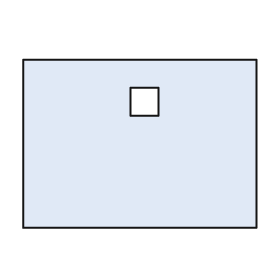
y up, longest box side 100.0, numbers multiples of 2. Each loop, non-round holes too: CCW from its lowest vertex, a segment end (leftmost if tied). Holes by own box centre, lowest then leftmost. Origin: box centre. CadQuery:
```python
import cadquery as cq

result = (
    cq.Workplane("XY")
    .moveTo(-50.0, -36.0)
    .lineTo(50.0, -36.0)
    .lineTo(50.0, 36.0)
    .lineTo(-50.0, 36.0)
    .close()
    .moveTo(-4.0, 12.0)
    .lineTo(8.0, 12.0)
    .lineTo(8.0, 24.0)
    .lineTo(-4.0, 24.0)
    .close()
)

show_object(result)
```